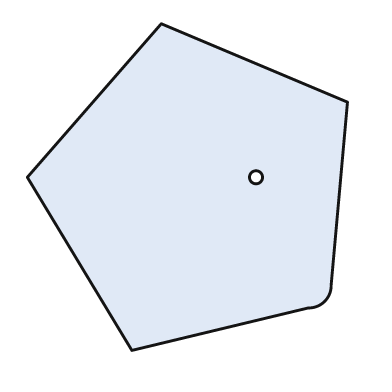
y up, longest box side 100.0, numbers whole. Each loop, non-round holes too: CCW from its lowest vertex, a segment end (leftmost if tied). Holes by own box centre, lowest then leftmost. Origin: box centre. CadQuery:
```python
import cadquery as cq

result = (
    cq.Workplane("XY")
    .moveTo(-17.0, -50.0)
    .lineTo(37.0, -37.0)
    .threePointArc((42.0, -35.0), (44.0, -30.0))
    .lineTo(49.0, 26.0)
    .lineTo(-8.0, 50.0)
    .lineTo(-49.0, 3.0)
    .close()
    .moveTo(21.0, 3.0)
    .circle(2.0)
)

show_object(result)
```